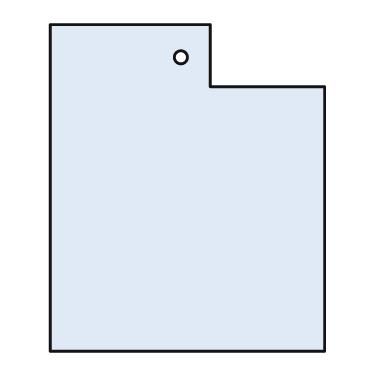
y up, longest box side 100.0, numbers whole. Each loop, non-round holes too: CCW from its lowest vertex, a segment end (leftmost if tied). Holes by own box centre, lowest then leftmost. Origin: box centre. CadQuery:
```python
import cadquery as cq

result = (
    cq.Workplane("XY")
    .moveTo(-42.0, -50.0)
    .lineTo(42.0, -50.0)
    .lineTo(42.0, 31.0)
    .lineTo(7.0, 31.0)
    .lineTo(7.0, 50.0)
    .lineTo(-42.0, 50.0)
    .close()
    .moveTo(-2.0, 40.0)
    .circle(2.0)
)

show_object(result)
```